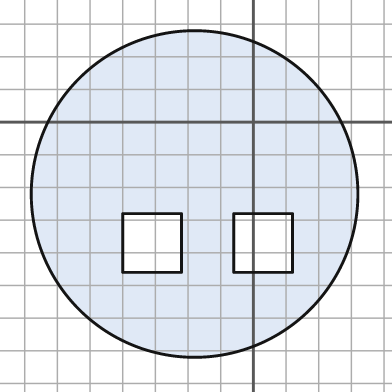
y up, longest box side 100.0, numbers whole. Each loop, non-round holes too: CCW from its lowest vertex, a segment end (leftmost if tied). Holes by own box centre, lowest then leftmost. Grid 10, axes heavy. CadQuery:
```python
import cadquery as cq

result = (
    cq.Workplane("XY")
    .moveTo(-18.0, -22.0)
    .circle(50.0)
    .moveTo(-40.0, -46.0)
    .lineTo(-22.0, -46.0)
    .lineTo(-22.0, -28.0)
    .lineTo(-40.0, -28.0)
    .close()
    .moveTo(-6.0, -46.0)
    .lineTo(12.0, -46.0)
    .lineTo(12.0, -28.0)
    .lineTo(-6.0, -28.0)
    .close()
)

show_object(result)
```